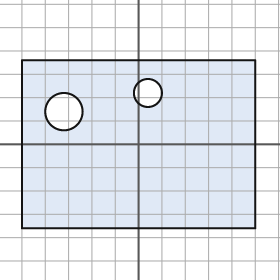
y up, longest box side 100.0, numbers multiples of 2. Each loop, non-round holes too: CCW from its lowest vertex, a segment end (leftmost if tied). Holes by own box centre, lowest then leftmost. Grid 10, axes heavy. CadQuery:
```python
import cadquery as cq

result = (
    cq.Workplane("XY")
    .moveTo(-50.0, -36.0)
    .lineTo(50.0, -36.0)
    .lineTo(50.0, 36.0)
    .lineTo(-50.0, 36.0)
    .close()
    .moveTo(-32.0, 14.0)
    .circle(8.0)
    .moveTo(4.0, 22.0)
    .circle(6.0)
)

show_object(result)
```